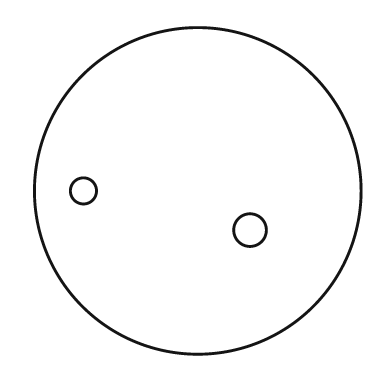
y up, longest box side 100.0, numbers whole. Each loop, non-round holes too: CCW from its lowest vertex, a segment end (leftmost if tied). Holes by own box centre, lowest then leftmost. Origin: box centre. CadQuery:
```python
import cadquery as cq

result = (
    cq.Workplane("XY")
    .moveTo(0.0, 0.0)
    .circle(50.0)
    .moveTo(16.0, -12.0)
    .circle(5.0)
    .moveTo(-35.0, 0.0)
    .circle(4.0)
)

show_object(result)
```